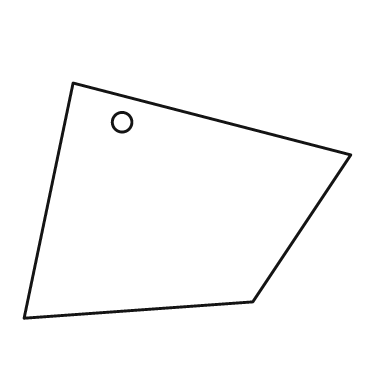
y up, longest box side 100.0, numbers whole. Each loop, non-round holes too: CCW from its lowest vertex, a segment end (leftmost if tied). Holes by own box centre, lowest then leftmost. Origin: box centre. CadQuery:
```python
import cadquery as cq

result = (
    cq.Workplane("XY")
    .moveTo(-50.0, -36.0)
    .lineTo(20.0, -31.0)
    .lineTo(50.0, 14.0)
    .lineTo(-35.0, 36.0)
    .close()
    .moveTo(-20.0, 24.0)
    .circle(3.0)
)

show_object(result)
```